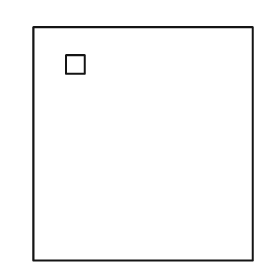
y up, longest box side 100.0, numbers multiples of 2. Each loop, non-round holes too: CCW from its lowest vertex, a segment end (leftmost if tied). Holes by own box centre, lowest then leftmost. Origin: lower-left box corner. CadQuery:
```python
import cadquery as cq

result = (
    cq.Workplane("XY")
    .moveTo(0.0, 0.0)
    .lineTo(94.0, 0.0)
    .lineTo(94.0, 100.0)
    .lineTo(0.0, 100.0)
    .close()
    .moveTo(14.0, 80.0)
    .lineTo(22.0, 80.0)
    .lineTo(22.0, 88.0)
    .lineTo(14.0, 88.0)
    .close()
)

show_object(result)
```